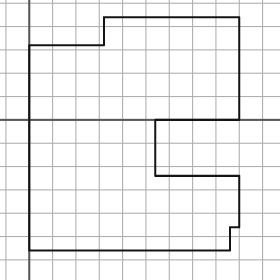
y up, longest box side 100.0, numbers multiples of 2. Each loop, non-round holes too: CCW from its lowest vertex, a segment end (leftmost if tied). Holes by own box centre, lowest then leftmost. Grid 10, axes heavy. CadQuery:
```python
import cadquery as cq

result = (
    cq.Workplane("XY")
    .moveTo(0.0, -56.0)
    .lineTo(86.0, -56.0)
    .lineTo(86.0, -46.0)
    .lineTo(90.0, -46.0)
    .lineTo(90.0, -24.0)
    .lineTo(54.0, -24.0)
    .lineTo(54.0, 0.0)
    .lineTo(90.0, 0.0)
    .lineTo(90.0, 44.0)
    .lineTo(32.0, 44.0)
    .lineTo(32.0, 32.0)
    .lineTo(0.0, 32.0)
    .close()
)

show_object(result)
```